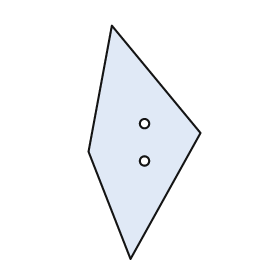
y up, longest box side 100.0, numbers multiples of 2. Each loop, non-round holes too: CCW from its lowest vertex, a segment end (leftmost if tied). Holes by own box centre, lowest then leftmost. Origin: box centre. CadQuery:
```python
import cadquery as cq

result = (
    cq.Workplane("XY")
    .moveTo(-6.0, -50.0)
    .lineTo(24.0, 4.0)
    .lineTo(-14.0, 50.0)
    .lineTo(-24.0, -4.0)
    .close()
    .moveTo(0.0, -8.0)
    .circle(2.0)
    .moveTo(0.0, 8.0)
    .circle(2.0)
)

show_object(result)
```